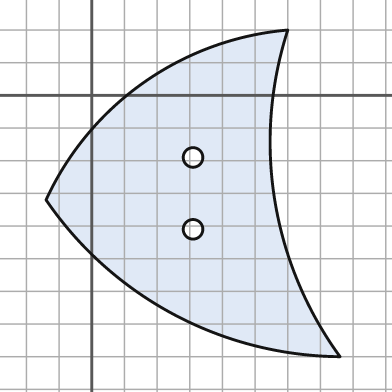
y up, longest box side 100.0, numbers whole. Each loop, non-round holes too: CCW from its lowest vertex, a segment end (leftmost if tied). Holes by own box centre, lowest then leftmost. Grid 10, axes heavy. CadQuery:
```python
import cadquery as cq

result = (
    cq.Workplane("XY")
    .moveTo(76.0, -80.0)
    .threePointArc((56.0, -32.0), (60.0, 20.0))
    .threePointArc((16.0, 4.0), (-14.0, -32.0))
    .threePointArc((25.0, -67.0), (76.0, -80.0))
    .close()
    .moveTo(31.0, -41.0)
    .circle(3.0)
    .moveTo(31.0, -19.0)
    .circle(3.0)
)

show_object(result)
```